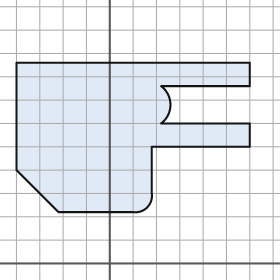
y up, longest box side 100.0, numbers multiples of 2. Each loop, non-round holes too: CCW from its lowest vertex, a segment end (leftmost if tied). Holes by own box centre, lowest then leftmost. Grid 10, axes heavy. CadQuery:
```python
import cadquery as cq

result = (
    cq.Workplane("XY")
    .moveTo(-22.0, 22.0)
    .lineTo(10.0, 22.0)
    .threePointArc((16.0, 24.0), (18.0, 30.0))
    .lineTo(18.0, 50.0)
    .lineTo(60.0, 50.0)
    .lineTo(60.0, 60.0)
    .lineTo(22.0, 60.0)
    .threePointArc((26.0, 68.0), (22.0, 76.0))
    .lineTo(60.0, 76.0)
    .lineTo(60.0, 86.0)
    .lineTo(-40.0, 86.0)
    .lineTo(-40.0, 40.0)
    .close()
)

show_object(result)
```